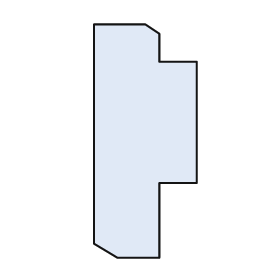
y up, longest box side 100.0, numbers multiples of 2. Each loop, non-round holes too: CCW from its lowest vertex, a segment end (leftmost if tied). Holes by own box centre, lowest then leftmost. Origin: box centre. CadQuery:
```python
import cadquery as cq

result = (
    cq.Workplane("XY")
    .moveTo(-12.0, -50.0)
    .lineTo(6.0, -50.0)
    .lineTo(6.0, -18.0)
    .lineTo(22.0, -18.0)
    .lineTo(22.0, 34.0)
    .lineTo(6.0, 34.0)
    .lineTo(6.0, 46.0)
    .lineTo(0.0, 50.0)
    .lineTo(-22.0, 50.0)
    .lineTo(-22.0, -44.0)
    .close()
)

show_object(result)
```